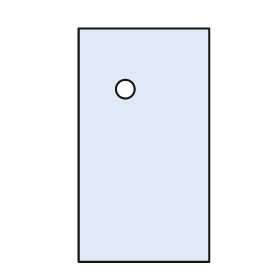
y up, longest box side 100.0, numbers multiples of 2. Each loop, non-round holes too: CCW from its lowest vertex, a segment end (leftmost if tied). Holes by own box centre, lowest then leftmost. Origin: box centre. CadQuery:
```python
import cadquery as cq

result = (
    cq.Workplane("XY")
    .moveTo(-28.0, -50.0)
    .lineTo(28.0, -50.0)
    .lineTo(28.0, 50.0)
    .lineTo(-28.0, 50.0)
    .close()
    .moveTo(-8.0, 24.0)
    .circle(4.0)
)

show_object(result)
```